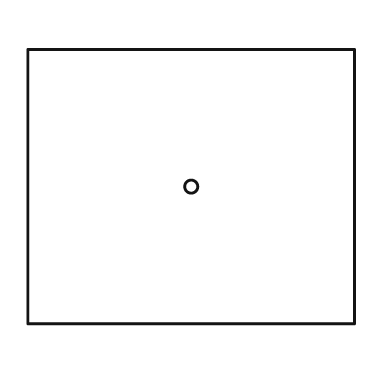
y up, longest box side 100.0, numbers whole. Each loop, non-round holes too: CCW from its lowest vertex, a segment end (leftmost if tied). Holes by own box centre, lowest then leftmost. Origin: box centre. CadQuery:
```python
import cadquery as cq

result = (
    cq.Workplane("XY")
    .moveTo(-50.0, -42.0)
    .lineTo(50.0, -42.0)
    .lineTo(50.0, 42.0)
    .lineTo(-50.0, 42.0)
    .close()
    .moveTo(0.0, 0.0)
    .circle(2.0)
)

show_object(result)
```